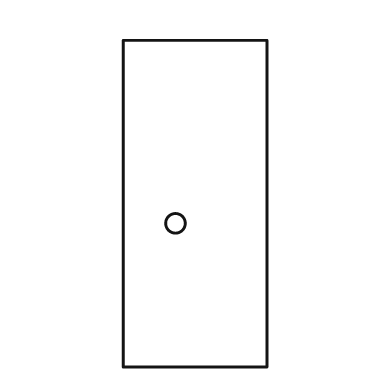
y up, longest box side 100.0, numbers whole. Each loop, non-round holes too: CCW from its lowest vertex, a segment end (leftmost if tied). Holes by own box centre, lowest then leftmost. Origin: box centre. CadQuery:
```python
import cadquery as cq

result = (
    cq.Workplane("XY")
    .moveTo(-22.0, -50.0)
    .lineTo(22.0, -50.0)
    .lineTo(22.0, 50.0)
    .lineTo(-22.0, 50.0)
    .close()
    .moveTo(-6.0, -6.0)
    .circle(3.0)
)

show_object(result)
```